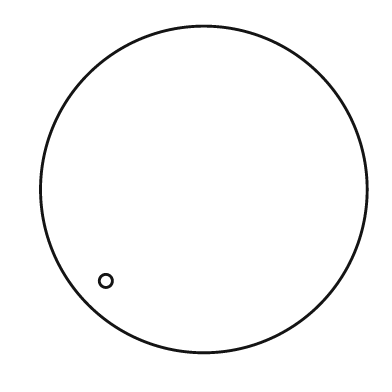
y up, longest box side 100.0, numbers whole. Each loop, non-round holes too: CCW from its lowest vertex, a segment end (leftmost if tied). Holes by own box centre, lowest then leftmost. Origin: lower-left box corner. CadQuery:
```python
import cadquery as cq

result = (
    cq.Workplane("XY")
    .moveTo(50.0, 50.0)
    .circle(50.0)
    .moveTo(20.0, 22.0)
    .circle(2.0)
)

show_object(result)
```